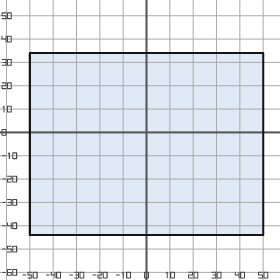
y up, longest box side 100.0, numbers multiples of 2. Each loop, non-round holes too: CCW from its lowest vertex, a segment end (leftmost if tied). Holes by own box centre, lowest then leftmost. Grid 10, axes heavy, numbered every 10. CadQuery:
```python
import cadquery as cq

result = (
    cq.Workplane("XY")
    .moveTo(-50.0, -44.0)
    .lineTo(50.0, -44.0)
    .lineTo(50.0, 34.0)
    .lineTo(-50.0, 34.0)
    .close()
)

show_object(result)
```